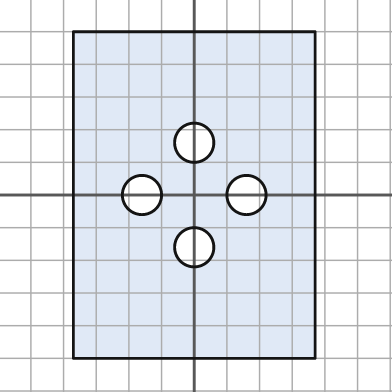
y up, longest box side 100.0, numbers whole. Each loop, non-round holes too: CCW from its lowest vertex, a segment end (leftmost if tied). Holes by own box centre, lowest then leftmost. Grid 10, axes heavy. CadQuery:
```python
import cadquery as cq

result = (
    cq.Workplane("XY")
    .moveTo(-37.0, -50.0)
    .lineTo(37.0, -50.0)
    .lineTo(37.0, 50.0)
    .lineTo(-37.0, 50.0)
    .close()
    .moveTo(0.0, -16.0)
    .circle(6.0)
    .moveTo(-16.0, 0.0)
    .circle(6.0)
    .moveTo(16.0, 0.0)
    .circle(6.0)
    .moveTo(0.0, 16.0)
    .circle(6.0)
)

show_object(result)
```